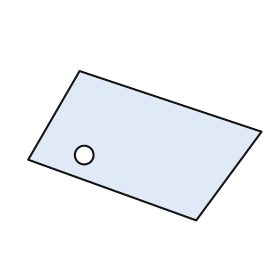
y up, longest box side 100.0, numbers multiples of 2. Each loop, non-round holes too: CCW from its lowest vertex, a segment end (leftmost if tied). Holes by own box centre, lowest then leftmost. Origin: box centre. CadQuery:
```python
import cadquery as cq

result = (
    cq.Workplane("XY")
    .moveTo(22.0, -32.0)
    .lineTo(50.0, 6.0)
    .lineTo(-28.0, 32.0)
    .lineTo(-50.0, -6.0)
    .close()
    .moveTo(-26.0, -4.0)
    .circle(4.0)
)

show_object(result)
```